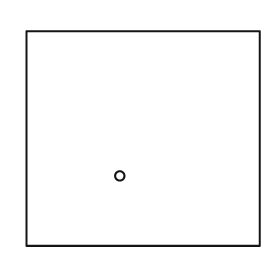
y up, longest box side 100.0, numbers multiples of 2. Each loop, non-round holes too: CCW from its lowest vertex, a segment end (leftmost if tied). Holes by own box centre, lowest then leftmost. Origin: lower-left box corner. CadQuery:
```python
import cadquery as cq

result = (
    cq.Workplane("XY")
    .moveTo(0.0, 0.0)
    .lineTo(100.0, 0.0)
    .lineTo(100.0, 92.0)
    .lineTo(0.0, 92.0)
    .close()
    .moveTo(40.0, 30.0)
    .circle(2.0)
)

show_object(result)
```